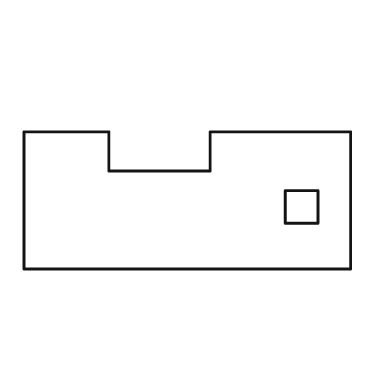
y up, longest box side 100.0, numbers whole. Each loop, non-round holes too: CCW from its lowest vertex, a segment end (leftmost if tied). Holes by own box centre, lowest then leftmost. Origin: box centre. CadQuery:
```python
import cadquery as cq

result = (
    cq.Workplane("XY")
    .moveTo(-50.0, -21.0)
    .lineTo(50.0, -21.0)
    .lineTo(50.0, 21.0)
    .lineTo(7.0, 21.0)
    .lineTo(7.0, 9.0)
    .lineTo(-24.0, 9.0)
    .lineTo(-24.0, 21.0)
    .lineTo(-50.0, 21.0)
    .close()
    .moveTo(30.0, -7.0)
    .lineTo(40.0, -7.0)
    .lineTo(40.0, 3.0)
    .lineTo(30.0, 3.0)
    .close()
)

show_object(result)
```